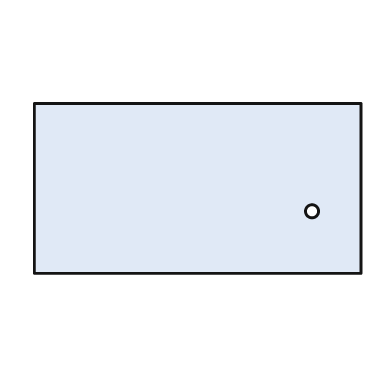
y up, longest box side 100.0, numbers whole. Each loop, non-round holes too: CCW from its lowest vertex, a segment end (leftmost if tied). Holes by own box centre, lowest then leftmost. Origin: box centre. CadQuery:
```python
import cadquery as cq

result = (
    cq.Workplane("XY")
    .moveTo(-50.0, -26.0)
    .lineTo(50.0, -26.0)
    .lineTo(50.0, 26.0)
    .lineTo(-50.0, 26.0)
    .close()
    .moveTo(35.0, -7.0)
    .circle(2.0)
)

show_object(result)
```